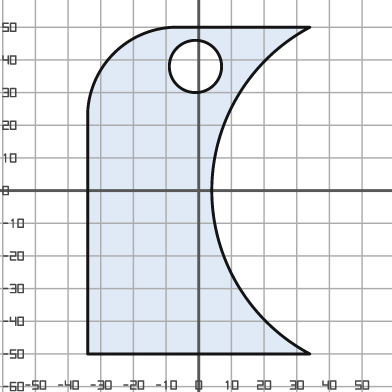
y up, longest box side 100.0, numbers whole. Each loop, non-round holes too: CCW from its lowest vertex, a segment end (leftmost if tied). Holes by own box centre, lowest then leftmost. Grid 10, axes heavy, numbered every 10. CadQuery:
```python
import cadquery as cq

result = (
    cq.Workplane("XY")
    .moveTo(-34.0, -50.0)
    .lineTo(34.0, -50.0)
    .threePointArc((4.0, 0.0), (34.0, 50.0))
    .lineTo(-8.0, 50.0)
    .threePointArc((-26.0, 42.0), (-34.0, 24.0))
    .close()
    .moveTo(-1.0, 38.0)
    .circle(8.0)
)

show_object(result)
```